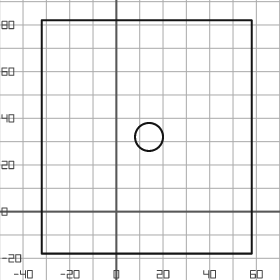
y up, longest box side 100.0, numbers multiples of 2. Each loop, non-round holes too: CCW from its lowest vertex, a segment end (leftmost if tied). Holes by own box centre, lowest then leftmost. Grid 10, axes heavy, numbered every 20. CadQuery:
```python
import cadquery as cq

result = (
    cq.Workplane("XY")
    .moveTo(-32.0, -18.0)
    .lineTo(58.0, -18.0)
    .lineTo(58.0, 82.0)
    .lineTo(-32.0, 82.0)
    .close()
    .moveTo(14.0, 32.0)
    .circle(6.0)
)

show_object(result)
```